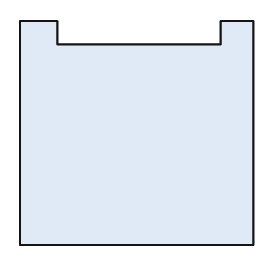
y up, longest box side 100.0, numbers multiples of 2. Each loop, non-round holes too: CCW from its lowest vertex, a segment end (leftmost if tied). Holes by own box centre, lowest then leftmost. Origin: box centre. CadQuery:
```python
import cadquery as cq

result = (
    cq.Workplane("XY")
    .moveTo(-50.0, -48.0)
    .lineTo(50.0, -48.0)
    .lineTo(50.0, 48.0)
    .lineTo(36.0, 48.0)
    .lineTo(36.0, 38.0)
    .lineTo(-34.0, 38.0)
    .lineTo(-34.0, 48.0)
    .lineTo(-50.0, 48.0)
    .close()
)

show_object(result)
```